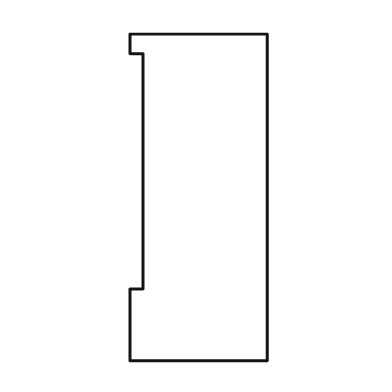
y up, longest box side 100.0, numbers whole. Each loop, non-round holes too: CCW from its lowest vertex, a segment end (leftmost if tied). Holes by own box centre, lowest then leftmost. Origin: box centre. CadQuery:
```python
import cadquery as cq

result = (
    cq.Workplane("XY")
    .moveTo(-21.0, -50.0)
    .lineTo(21.0, -50.0)
    .lineTo(21.0, 50.0)
    .lineTo(-21.0, 50.0)
    .lineTo(-21.0, 44.0)
    .lineTo(-17.0, 44.0)
    .lineTo(-17.0, -28.0)
    .lineTo(-21.0, -28.0)
    .close()
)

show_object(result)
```